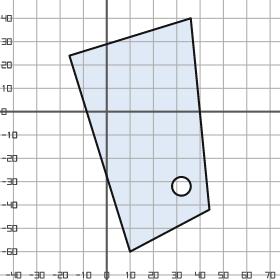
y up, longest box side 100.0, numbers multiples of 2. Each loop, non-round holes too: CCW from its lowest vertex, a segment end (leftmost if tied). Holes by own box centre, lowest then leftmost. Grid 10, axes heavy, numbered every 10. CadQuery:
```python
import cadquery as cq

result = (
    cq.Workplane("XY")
    .moveTo(10.0, -60.0)
    .lineTo(44.0, -42.0)
    .lineTo(36.0, 40.0)
    .lineTo(-16.0, 24.0)
    .close()
    .moveTo(32.0, -32.0)
    .circle(4.0)
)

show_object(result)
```